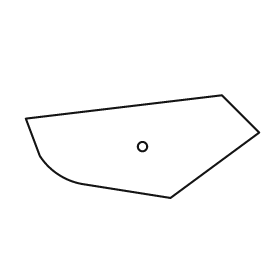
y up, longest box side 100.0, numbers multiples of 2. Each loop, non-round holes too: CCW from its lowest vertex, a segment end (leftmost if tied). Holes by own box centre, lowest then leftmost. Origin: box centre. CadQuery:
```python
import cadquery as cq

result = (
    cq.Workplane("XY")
    .moveTo(12.0, -22.0)
    .lineTo(50.0, 6.0)
    .lineTo(34.0, 22.0)
    .lineTo(-50.0, 12.0)
    .lineTo(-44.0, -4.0)
    .threePointArc((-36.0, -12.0), (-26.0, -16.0))
    .close()
    .moveTo(0.0, 0.0)
    .circle(2.0)
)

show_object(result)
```